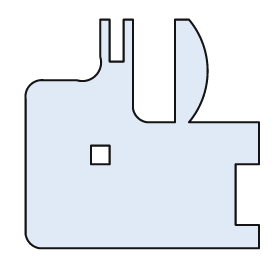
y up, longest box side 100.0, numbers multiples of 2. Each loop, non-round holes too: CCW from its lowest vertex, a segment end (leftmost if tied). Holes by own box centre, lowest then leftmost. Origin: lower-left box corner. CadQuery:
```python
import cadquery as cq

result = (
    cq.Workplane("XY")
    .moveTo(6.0, 0.0)
    .lineTo(100.0, 0.0)
    .lineTo(100.0, 10.0)
    .lineTo(90.0, 10.0)
    .lineTo(90.0, 36.0)
    .lineTo(100.0, 36.0)
    .lineTo(100.0, 54.0)
    .lineTo(70.0, 54.0)
    .threePointArc((78.0, 76.0), (70.0, 98.0))
    .lineTo(64.0, 98.0)
    .lineTo(64.0, 54.0)
    .lineTo(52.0, 54.0)
    .threePointArc((48.0, 56.0), (46.0, 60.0))
    .lineTo(46.0, 98.0)
    .lineTo(42.0, 98.0)
    .lineTo(42.0, 80.0)
    .lineTo(36.0, 80.0)
    .lineTo(36.0, 98.0)
    .lineTo(32.0, 98.0)
    .lineTo(32.0, 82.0)
    .threePointArc((30.0, 74.0), (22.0, 72.0))
    .lineTo(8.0, 72.0)
    .threePointArc((2.0, 70.0), (0.0, 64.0))
    .lineTo(0.0, 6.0)
    .threePointArc((2.0, 2.0), (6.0, 0.0))
    .close()
    .moveTo(28.0, 36.0)
    .lineTo(36.0, 36.0)
    .lineTo(36.0, 44.0)
    .lineTo(28.0, 44.0)
    .close()
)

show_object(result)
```